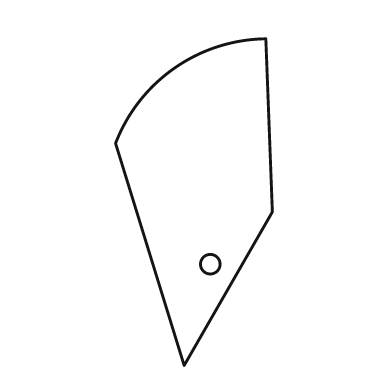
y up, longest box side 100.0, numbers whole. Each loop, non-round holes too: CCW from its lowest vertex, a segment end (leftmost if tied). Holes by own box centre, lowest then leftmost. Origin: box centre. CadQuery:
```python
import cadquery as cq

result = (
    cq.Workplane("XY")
    .moveTo(-3.0, -50.0)
    .lineTo(24.0, -3.0)
    .lineTo(22.0, 50.0)
    .threePointArc((-6.0, 41.0), (-24.0, 18.0))
    .close()
    .moveTo(5.0, -19.0)
    .circle(3.0)
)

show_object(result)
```